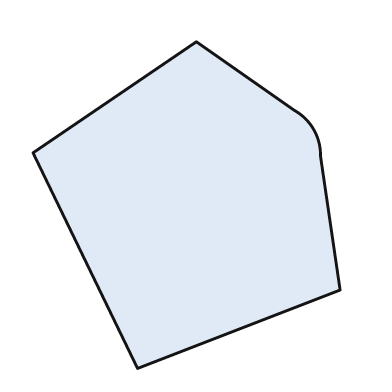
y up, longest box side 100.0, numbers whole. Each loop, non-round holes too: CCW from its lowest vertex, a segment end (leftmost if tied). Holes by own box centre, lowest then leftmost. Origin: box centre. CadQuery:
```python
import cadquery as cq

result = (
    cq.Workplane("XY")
    .moveTo(-15.0, -50.0)
    .lineTo(47.0, -26.0)
    .lineTo(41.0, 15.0)
    .threePointArc((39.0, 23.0), (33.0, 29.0))
    .lineTo(3.0, 50.0)
    .lineTo(-47.0, 16.0)
    .close()
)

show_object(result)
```